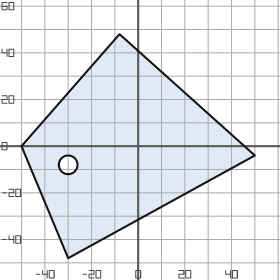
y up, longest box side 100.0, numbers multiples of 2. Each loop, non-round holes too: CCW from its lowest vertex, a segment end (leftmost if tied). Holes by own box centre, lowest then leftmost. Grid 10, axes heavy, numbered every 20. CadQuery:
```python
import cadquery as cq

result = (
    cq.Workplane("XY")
    .moveTo(-30.0, -48.0)
    .lineTo(50.0, -4.0)
    .lineTo(-8.0, 48.0)
    .lineTo(-50.0, 0.0)
    .close()
    .moveTo(-30.0, -8.0)
    .circle(4.0)
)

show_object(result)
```